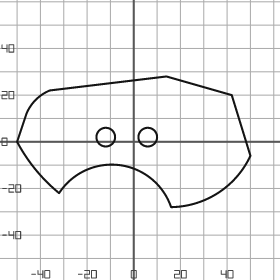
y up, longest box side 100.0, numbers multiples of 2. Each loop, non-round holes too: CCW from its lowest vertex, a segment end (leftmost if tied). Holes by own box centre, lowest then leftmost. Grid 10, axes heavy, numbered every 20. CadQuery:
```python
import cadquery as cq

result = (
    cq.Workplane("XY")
    .moveTo(16.0, -28.0)
    .threePointArc((36.0, -22.0), (50.0, -6.0))
    .lineTo(42.0, 20.0)
    .lineTo(14.0, 28.0)
    .lineTo(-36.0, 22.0)
    .threePointArc((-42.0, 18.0), (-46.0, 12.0))
    .lineTo(-50.0, 0.0)
    .threePointArc((-42.0, -12.0), (-32.0, -22.0))
    .threePointArc((-6.0, -10.0), (16.0, -28.0))
    .close()
    .moveTo(-12.0, 2.0)
    .circle(4.0)
    .moveTo(6.0, 2.0)
    .circle(4.0)
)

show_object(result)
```